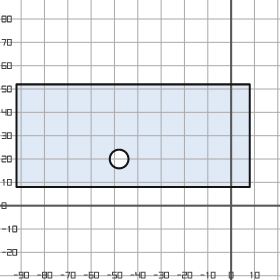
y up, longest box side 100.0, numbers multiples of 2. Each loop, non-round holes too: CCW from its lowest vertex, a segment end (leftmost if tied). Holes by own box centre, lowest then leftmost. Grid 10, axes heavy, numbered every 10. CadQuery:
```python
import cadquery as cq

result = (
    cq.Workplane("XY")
    .moveTo(-92.0, 8.0)
    .lineTo(8.0, 8.0)
    .lineTo(8.0, 52.0)
    .lineTo(-92.0, 52.0)
    .close()
    .moveTo(-48.0, 20.0)
    .circle(4.0)
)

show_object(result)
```